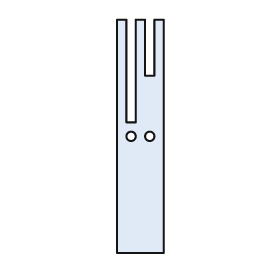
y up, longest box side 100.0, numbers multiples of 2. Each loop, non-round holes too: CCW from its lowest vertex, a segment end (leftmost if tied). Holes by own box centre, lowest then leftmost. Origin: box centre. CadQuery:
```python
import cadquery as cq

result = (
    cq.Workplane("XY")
    .moveTo(-10.0, -50.0)
    .lineTo(10.0, -50.0)
    .lineTo(10.0, 50.0)
    .lineTo(6.0, 50.0)
    .lineTo(6.0, 26.0)
    .lineTo(2.0, 26.0)
    .lineTo(2.0, 50.0)
    .lineTo(-2.0, 50.0)
    .lineTo(-2.0, 6.0)
    .lineTo(-6.0, 6.0)
    .lineTo(-6.0, 50.0)
    .lineTo(-10.0, 50.0)
    .close()
    .moveTo(-4.0, 0.0)
    .circle(2.0)
    .moveTo(4.0, 0.0)
    .circle(2.0)
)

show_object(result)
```